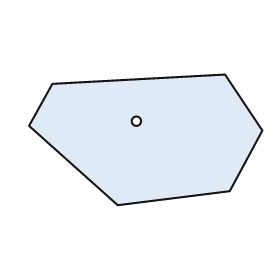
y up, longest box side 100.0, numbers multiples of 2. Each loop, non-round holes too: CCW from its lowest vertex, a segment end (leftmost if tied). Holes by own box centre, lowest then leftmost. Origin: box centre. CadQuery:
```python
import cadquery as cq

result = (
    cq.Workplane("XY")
    .moveTo(-12.0, -28.0)
    .lineTo(36.0, -22.0)
    .lineTo(50.0, 4.0)
    .lineTo(34.0, 28.0)
    .lineTo(-40.0, 24.0)
    .lineTo(-50.0, 6.0)
    .close()
    .moveTo(-4.0, 8.0)
    .circle(2.0)
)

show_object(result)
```